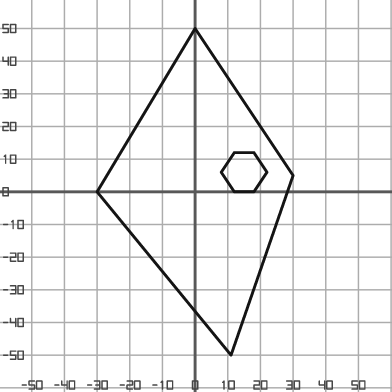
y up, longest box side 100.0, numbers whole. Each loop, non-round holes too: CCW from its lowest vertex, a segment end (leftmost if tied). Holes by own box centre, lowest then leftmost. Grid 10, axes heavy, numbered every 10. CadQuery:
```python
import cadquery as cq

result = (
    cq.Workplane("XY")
    .moveTo(11.0, -50.0)
    .lineTo(30.0, 5.0)
    .lineTo(0.0, 50.0)
    .lineTo(-30.0, 0.0)
    .close()
    .moveTo(12.0, 0.0)
    .lineTo(18.0, 0.0)
    .lineTo(22.0, 6.0)
    .lineTo(18.0, 12.0)
    .lineTo(12.0, 12.0)
    .lineTo(8.0, 6.0)
    .close()
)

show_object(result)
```